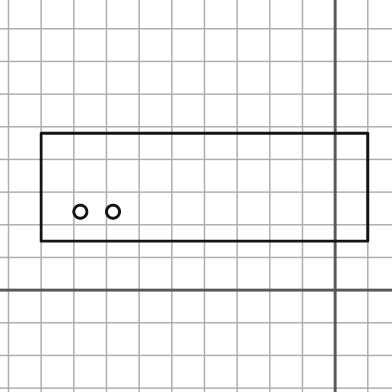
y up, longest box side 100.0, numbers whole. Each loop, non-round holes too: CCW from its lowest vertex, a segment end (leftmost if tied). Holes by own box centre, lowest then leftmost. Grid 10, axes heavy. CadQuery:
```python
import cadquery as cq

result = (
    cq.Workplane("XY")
    .moveTo(-90.0, 15.0)
    .lineTo(10.0, 15.0)
    .lineTo(10.0, 48.0)
    .lineTo(-90.0, 48.0)
    .close()
    .moveTo(-78.0, 24.0)
    .circle(2.0)
    .moveTo(-68.0, 24.0)
    .circle(2.0)
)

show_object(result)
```